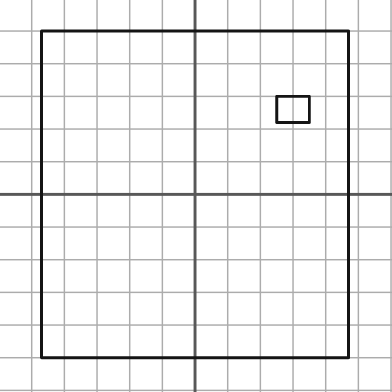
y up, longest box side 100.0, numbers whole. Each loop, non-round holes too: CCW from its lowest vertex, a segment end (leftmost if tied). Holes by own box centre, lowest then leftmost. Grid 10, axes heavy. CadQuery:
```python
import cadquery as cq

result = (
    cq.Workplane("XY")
    .moveTo(-47.0, -50.0)
    .lineTo(47.0, -50.0)
    .lineTo(47.0, 50.0)
    .lineTo(-47.0, 50.0)
    .close()
    .moveTo(25.0, 22.0)
    .lineTo(35.0, 22.0)
    .lineTo(35.0, 30.0)
    .lineTo(25.0, 30.0)
    .close()
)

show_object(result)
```